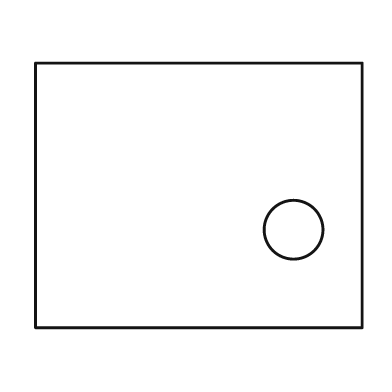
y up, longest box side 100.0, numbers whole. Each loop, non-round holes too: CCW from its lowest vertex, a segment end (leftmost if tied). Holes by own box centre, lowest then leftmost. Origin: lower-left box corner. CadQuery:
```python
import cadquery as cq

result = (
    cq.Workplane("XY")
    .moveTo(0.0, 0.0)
    .lineTo(100.0, 0.0)
    .lineTo(100.0, 81.0)
    .lineTo(0.0, 81.0)
    .close()
    .moveTo(79.0, 30.0)
    .circle(9.0)
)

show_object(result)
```